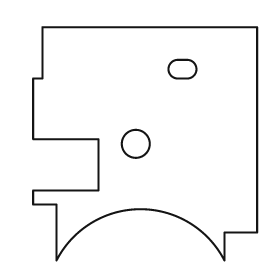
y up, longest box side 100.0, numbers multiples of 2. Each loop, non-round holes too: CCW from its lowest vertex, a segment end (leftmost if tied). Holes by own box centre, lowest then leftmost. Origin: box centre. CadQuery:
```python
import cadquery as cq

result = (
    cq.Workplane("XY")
    .moveTo(-38.0, -50.0)
    .threePointArc((-2.0, -28.0), (34.0, -50.0))
    .lineTo(34.0, -38.0)
    .lineTo(48.0, -38.0)
    .lineTo(48.0, 50.0)
    .lineTo(-44.0, 50.0)
    .lineTo(-44.0, 28.0)
    .lineTo(-48.0, 28.0)
    .lineTo(-48.0, 2.0)
    .lineTo(-20.0, 2.0)
    .lineTo(-20.0, -20.0)
    .lineTo(-48.0, -20.0)
    .lineTo(-48.0, -26.0)
    .lineTo(-38.0, -26.0)
    .close()
    .moveTo(-4.0, 0.0)
    .circle(6.0)
    .moveTo(14.0, 28.0)
    .lineTo(18.0, 28.0)
    .threePointArc((22.0, 32.0), (18.0, 36.0))
    .lineTo(14.0, 36.0)
    .threePointArc((10.0, 32.0), (14.0, 28.0))
    .close()
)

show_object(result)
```